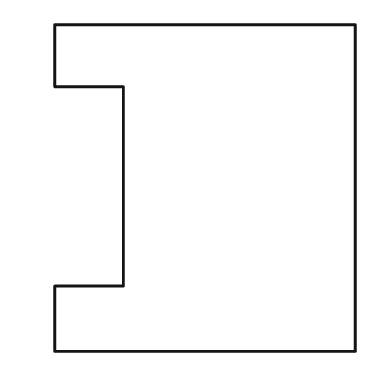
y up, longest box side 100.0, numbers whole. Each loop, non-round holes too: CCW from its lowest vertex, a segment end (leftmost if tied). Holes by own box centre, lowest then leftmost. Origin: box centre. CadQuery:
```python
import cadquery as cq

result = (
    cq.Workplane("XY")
    .moveTo(-46.0, -50.0)
    .lineTo(46.0, -50.0)
    .lineTo(46.0, 50.0)
    .lineTo(-46.0, 50.0)
    .lineTo(-46.0, 31.0)
    .lineTo(-25.0, 31.0)
    .lineTo(-25.0, -30.0)
    .lineTo(-46.0, -30.0)
    .close()
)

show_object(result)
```